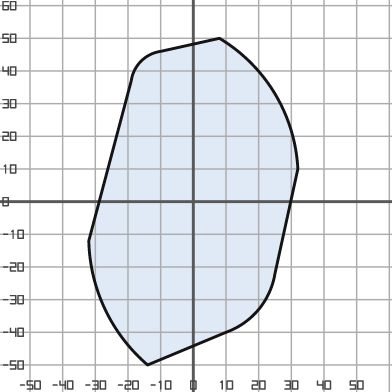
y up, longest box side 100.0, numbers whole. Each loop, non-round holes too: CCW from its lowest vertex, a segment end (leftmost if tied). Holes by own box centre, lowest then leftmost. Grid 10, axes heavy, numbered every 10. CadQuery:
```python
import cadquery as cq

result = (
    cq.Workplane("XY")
    .moveTo(-14.0, -50.0)
    .lineTo(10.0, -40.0)
    .threePointArc((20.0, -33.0), (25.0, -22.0))
    .lineTo(32.0, 10.0)
    .threePointArc((25.0, 33.0), (8.0, 50.0))
    .lineTo(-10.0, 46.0)
    .threePointArc((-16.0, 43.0), (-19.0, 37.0))
    .lineTo(-32.0, -12.0)
    .threePointArc((-27.0, -33.0), (-14.0, -50.0))
    .close()
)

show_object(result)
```